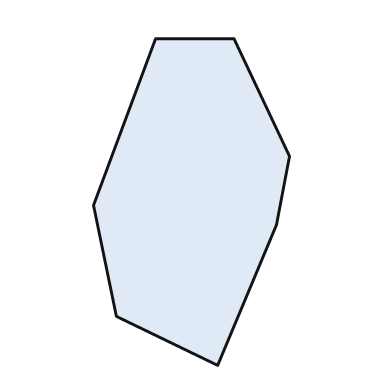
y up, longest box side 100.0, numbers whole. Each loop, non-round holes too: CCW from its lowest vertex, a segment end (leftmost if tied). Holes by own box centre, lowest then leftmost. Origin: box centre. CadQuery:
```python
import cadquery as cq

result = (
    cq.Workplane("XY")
    .moveTo(8.0, -50.0)
    .lineTo(26.0, -7.0)
    .lineTo(30.0, 14.0)
    .lineTo(13.0, 50.0)
    .lineTo(-11.0, 50.0)
    .lineTo(-30.0, -1.0)
    .lineTo(-23.0, -35.0)
    .close()
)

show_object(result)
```